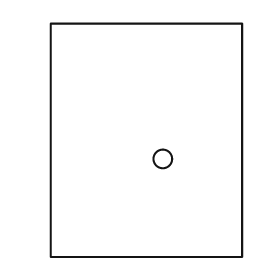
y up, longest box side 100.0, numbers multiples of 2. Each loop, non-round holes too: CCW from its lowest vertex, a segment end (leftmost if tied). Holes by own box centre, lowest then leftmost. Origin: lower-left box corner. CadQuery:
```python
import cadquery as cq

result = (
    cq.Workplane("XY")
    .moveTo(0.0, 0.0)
    .lineTo(82.0, 0.0)
    .lineTo(82.0, 100.0)
    .lineTo(0.0, 100.0)
    .close()
    .moveTo(48.0, 42.0)
    .circle(4.0)
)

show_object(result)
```